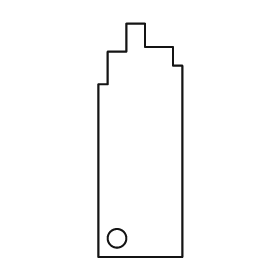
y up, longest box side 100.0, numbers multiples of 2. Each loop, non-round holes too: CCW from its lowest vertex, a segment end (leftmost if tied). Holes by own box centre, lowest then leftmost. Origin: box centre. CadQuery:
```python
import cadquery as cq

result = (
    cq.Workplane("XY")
    .moveTo(-18.0, -50.0)
    .lineTo(18.0, -50.0)
    .lineTo(18.0, 32.0)
    .lineTo(14.0, 32.0)
    .lineTo(14.0, 40.0)
    .lineTo(2.0, 40.0)
    .lineTo(2.0, 50.0)
    .lineTo(-6.0, 50.0)
    .lineTo(-6.0, 38.0)
    .lineTo(-14.0, 38.0)
    .lineTo(-14.0, 24.0)
    .lineTo(-18.0, 24.0)
    .close()
    .moveTo(-10.0, -42.0)
    .circle(4.0)
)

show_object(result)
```